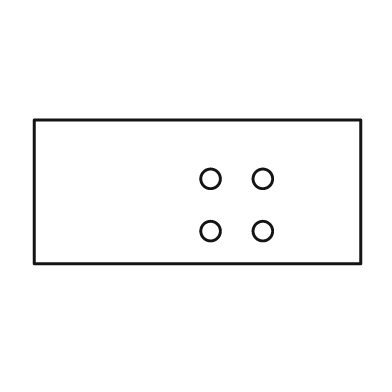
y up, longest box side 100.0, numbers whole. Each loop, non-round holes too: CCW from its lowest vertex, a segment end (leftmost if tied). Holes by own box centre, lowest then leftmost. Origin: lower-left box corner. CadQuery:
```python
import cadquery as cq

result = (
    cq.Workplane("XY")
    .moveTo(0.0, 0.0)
    .lineTo(100.0, 0.0)
    .lineTo(100.0, 44.0)
    .lineTo(0.0, 44.0)
    .close()
    .moveTo(54.0, 10.0)
    .circle(3.0)
    .moveTo(70.0, 10.0)
    .circle(3.0)
    .moveTo(54.0, 26.0)
    .circle(3.0)
    .moveTo(70.0, 26.0)
    .circle(3.0)
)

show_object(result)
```